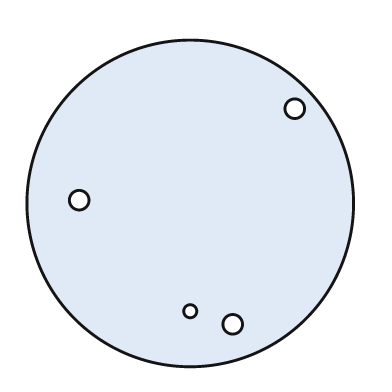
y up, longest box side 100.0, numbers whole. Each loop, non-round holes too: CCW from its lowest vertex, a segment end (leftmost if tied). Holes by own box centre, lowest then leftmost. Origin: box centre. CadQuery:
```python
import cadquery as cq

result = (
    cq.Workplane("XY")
    .moveTo(0.0, 0.0)
    .circle(50.0)
    .moveTo(13.0, -37.0)
    .circle(3.0)
    .moveTo(0.0, -33.0)
    .circle(2.0)
    .moveTo(-34.0, 1.0)
    .circle(3.0)
    .moveTo(32.0, 29.0)
    .circle(3.0)
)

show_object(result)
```